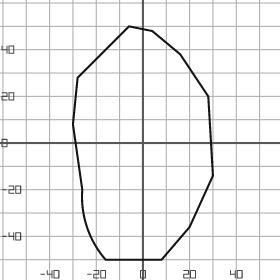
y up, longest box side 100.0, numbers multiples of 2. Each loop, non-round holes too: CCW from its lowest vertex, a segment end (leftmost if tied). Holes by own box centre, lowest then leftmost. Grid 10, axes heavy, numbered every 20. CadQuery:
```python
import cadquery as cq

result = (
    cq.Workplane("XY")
    .moveTo(-16.0, -50.0)
    .lineTo(8.0, -50.0)
    .lineTo(20.0, -36.0)
    .lineTo(30.0, -14.0)
    .lineTo(28.0, 20.0)
    .lineTo(16.0, 38.0)
    .lineTo(4.0, 48.0)
    .lineTo(-6.0, 50.0)
    .lineTo(-28.0, 28.0)
    .lineTo(-30.0, 8.0)
    .lineTo(-26.0, -20.0)
    .threePointArc((-24.0, -36.0), (-16.0, -50.0))
    .close()
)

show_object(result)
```